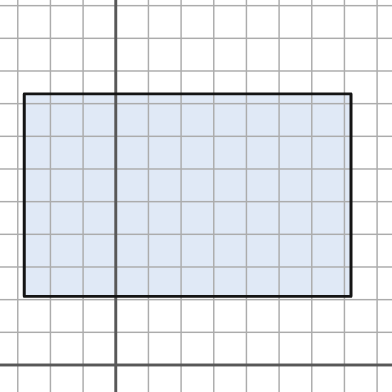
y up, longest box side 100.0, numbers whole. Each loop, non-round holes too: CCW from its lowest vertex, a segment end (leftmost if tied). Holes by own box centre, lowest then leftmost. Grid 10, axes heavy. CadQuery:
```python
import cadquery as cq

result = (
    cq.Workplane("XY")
    .moveTo(-28.0, 21.0)
    .lineTo(72.0, 21.0)
    .lineTo(72.0, 83.0)
    .lineTo(-28.0, 83.0)
    .close()
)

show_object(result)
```